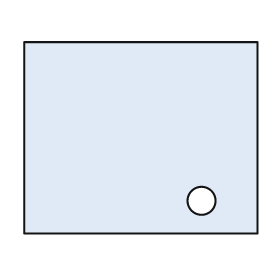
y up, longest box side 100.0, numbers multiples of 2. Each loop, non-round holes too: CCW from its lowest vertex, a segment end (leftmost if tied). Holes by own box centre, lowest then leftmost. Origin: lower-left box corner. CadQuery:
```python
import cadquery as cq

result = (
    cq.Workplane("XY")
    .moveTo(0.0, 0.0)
    .lineTo(100.0, 0.0)
    .lineTo(100.0, 82.0)
    .lineTo(0.0, 82.0)
    .close()
    .moveTo(76.0, 14.0)
    .circle(6.0)
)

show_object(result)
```